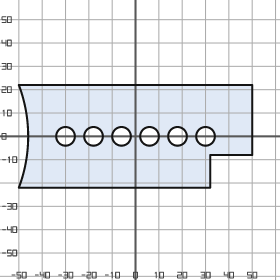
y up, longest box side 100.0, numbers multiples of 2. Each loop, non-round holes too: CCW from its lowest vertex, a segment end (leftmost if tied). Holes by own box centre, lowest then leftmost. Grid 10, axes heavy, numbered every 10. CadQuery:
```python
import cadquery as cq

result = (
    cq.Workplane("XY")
    .moveTo(-50.0, -22.0)
    .lineTo(32.0, -22.0)
    .lineTo(32.0, -8.0)
    .lineTo(50.0, -8.0)
    .lineTo(50.0, 22.0)
    .lineTo(-50.0, 22.0)
    .threePointArc((-46.0, 0.0), (-50.0, -22.0))
    .close()
    .moveTo(-30.0, 0.0)
    .circle(4.0)
    .moveTo(-18.0, 0.0)
    .circle(4.0)
    .moveTo(-6.0, 0.0)
    .circle(4.0)
    .moveTo(6.0, 0.0)
    .circle(4.0)
    .moveTo(18.0, 0.0)
    .circle(4.0)
    .moveTo(30.0, 0.0)
    .circle(4.0)
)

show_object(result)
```